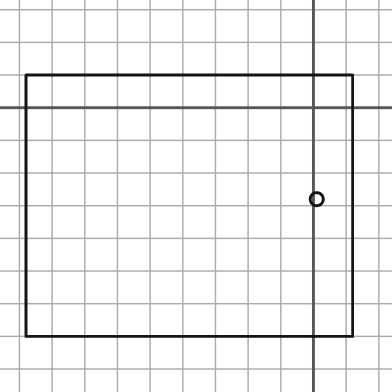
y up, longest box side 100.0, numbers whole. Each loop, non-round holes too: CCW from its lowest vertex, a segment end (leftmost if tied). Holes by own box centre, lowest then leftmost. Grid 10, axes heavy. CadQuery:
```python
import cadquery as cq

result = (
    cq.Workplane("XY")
    .moveTo(-88.0, -70.0)
    .lineTo(12.0, -70.0)
    .lineTo(12.0, 10.0)
    .lineTo(-88.0, 10.0)
    .close()
    .moveTo(1.0, -28.0)
    .circle(2.0)
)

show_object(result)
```